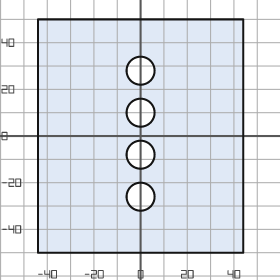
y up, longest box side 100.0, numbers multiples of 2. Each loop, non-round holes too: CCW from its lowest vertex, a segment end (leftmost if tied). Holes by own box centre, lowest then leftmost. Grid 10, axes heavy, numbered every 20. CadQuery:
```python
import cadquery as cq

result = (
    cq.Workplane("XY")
    .moveTo(-44.0, -50.0)
    .lineTo(44.0, -50.0)
    .lineTo(44.0, 50.0)
    .lineTo(-44.0, 50.0)
    .close()
    .moveTo(0.0, -26.0)
    .circle(6.0)
    .moveTo(0.0, -8.0)
    .circle(6.0)
    .moveTo(0.0, 10.0)
    .circle(6.0)
    .moveTo(0.0, 28.0)
    .circle(6.0)
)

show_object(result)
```